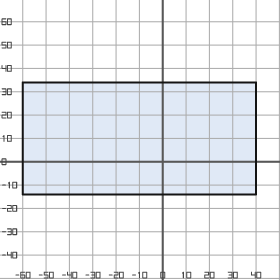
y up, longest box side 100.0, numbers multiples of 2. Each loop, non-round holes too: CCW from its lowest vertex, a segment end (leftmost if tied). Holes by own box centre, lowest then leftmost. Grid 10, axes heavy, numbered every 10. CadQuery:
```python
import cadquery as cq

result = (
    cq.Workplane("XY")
    .moveTo(-60.0, -14.0)
    .lineTo(40.0, -14.0)
    .lineTo(40.0, 34.0)
    .lineTo(-60.0, 34.0)
    .close()
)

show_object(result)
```